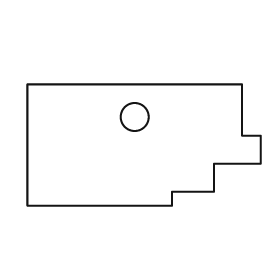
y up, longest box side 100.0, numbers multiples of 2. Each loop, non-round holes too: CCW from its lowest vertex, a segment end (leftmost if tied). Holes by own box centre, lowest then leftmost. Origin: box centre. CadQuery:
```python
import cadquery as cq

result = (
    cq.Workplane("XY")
    .moveTo(-50.0, -26.0)
    .lineTo(12.0, -26.0)
    .lineTo(12.0, -20.0)
    .lineTo(30.0, -20.0)
    .lineTo(30.0, -8.0)
    .lineTo(50.0, -8.0)
    .lineTo(50.0, 4.0)
    .lineTo(42.0, 4.0)
    .lineTo(42.0, 26.0)
    .lineTo(-50.0, 26.0)
    .close()
    .moveTo(-4.0, 12.0)
    .circle(6.0)
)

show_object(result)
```